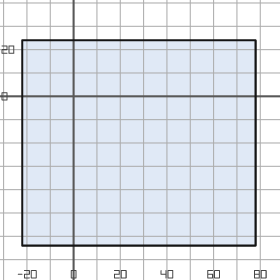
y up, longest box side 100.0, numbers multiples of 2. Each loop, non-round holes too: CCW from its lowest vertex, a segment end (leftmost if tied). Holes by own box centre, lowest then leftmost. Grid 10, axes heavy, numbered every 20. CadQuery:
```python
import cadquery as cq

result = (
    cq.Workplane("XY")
    .moveTo(-22.0, -64.0)
    .lineTo(78.0, -64.0)
    .lineTo(78.0, 24.0)
    .lineTo(-22.0, 24.0)
    .close()
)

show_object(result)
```